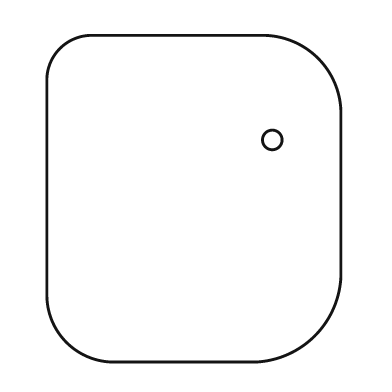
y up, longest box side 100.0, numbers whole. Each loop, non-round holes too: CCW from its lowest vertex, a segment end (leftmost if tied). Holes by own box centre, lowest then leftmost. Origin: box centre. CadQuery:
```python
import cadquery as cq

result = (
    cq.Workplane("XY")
    .moveTo(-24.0, -50.0)
    .lineTo(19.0, -50.0)
    .threePointArc((37.0, -42.0), (45.0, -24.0))
    .lineTo(45.0, 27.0)
    .threePointArc((38.0, 43.0), (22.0, 50.0))
    .lineTo(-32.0, 50.0)
    .threePointArc((-41.0, 46.0), (-45.0, 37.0))
    .lineTo(-45.0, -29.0)
    .threePointArc((-39.0, -44.0), (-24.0, -50.0))
    .close()
    .moveTo(24.0, 18.0)
    .circle(3.0)
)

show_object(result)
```